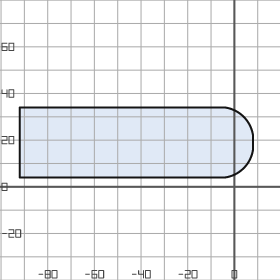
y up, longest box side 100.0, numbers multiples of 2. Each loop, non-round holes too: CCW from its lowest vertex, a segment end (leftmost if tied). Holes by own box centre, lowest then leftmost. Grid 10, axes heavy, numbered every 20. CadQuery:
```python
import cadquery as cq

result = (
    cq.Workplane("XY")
    .moveTo(-92.0, 4.0)
    .lineTo(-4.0, 4.0)
    .threePointArc((4.0, 8.0), (8.0, 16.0))
    .lineTo(8.0, 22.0)
    .threePointArc((4.0, 30.0), (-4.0, 34.0))
    .lineTo(-92.0, 34.0)
    .close()
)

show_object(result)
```